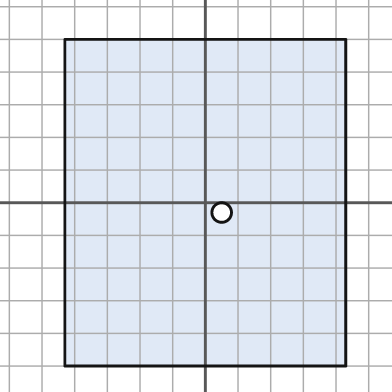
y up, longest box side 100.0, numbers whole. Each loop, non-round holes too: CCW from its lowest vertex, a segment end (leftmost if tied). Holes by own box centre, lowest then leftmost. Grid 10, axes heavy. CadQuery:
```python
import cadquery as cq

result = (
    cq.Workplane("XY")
    .moveTo(-43.0, -50.0)
    .lineTo(43.0, -50.0)
    .lineTo(43.0, 50.0)
    .lineTo(-43.0, 50.0)
    .close()
    .moveTo(5.0, -3.0)
    .circle(3.0)
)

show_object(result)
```